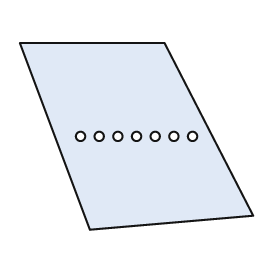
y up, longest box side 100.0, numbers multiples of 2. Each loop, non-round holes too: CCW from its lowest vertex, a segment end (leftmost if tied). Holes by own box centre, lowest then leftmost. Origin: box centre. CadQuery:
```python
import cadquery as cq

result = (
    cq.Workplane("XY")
    .moveTo(-20.0, -40.0)
    .lineTo(50.0, -34.0)
    .lineTo(12.0, 40.0)
    .lineTo(-50.0, 40.0)
    .close()
    .moveTo(-24.0, 0.0)
    .circle(2.0)
    .moveTo(-16.0, 0.0)
    .circle(2.0)
    .moveTo(-8.0, 0.0)
    .circle(2.0)
    .moveTo(0.0, 0.0)
    .circle(2.0)
    .moveTo(8.0, 0.0)
    .circle(2.0)
    .moveTo(16.0, 0.0)
    .circle(2.0)
    .moveTo(24.0, 0.0)
    .circle(2.0)
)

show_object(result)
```